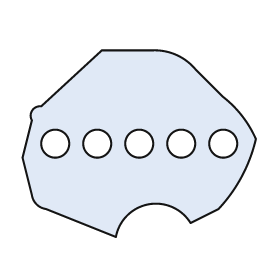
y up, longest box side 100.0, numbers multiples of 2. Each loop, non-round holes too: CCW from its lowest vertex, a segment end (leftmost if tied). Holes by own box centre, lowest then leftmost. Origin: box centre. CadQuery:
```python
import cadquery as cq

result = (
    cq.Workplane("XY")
    .moveTo(-10.0, -40.0)
    .threePointArc((4.0, -26.0), (22.0, -34.0))
    .lineTo(34.0, -28.0)
    .threePointArc((44.0, -14.0), (50.0, 2.0))
    .threePointArc((44.0, 12.0), (36.0, 20.0))
    .lineTo(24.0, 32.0)
    .threePointArc((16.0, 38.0), (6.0, 40.0))
    .lineTo(-16.0, 40.0)
    .lineTo(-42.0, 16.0)
    .threePointArc((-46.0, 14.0), (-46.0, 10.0))
    .lineTo(-50.0, -6.0)
    .lineTo(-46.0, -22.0)
    .threePointArc((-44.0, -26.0), (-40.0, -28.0))
    .close()
    .moveTo(-36.0, 0.0)
    .circle(6.0)
    .moveTo(-18.0, 0.0)
    .circle(6.0)
    .moveTo(0.0, 0.0)
    .circle(6.0)
    .moveTo(18.0, 0.0)
    .circle(6.0)
    .moveTo(36.0, 0.0)
    .circle(6.0)
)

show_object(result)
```